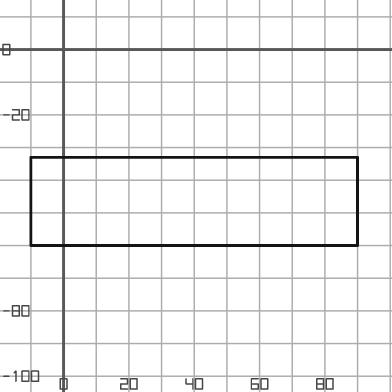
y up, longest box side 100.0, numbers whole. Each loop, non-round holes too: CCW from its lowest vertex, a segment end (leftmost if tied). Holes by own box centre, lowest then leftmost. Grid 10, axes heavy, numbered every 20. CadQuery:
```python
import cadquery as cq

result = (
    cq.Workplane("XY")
    .moveTo(-10.0, -60.0)
    .lineTo(90.0, -60.0)
    .lineTo(90.0, -33.0)
    .lineTo(-10.0, -33.0)
    .close()
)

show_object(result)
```